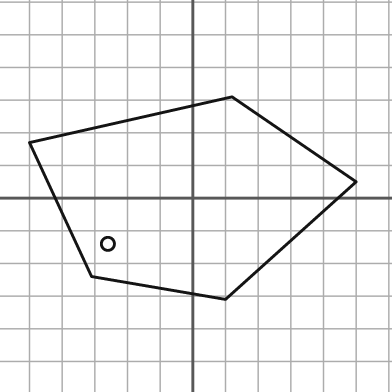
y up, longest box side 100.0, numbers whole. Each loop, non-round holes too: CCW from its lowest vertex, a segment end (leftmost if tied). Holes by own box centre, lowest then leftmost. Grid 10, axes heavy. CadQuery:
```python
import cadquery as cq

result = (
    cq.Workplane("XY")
    .moveTo(10.0, -31.0)
    .lineTo(50.0, 5.0)
    .lineTo(12.0, 31.0)
    .lineTo(-50.0, 17.0)
    .lineTo(-31.0, -24.0)
    .close()
    .moveTo(-26.0, -14.0)
    .circle(2.0)
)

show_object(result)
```